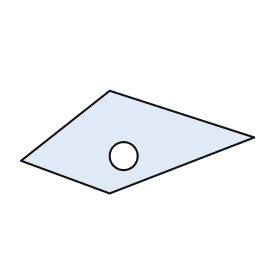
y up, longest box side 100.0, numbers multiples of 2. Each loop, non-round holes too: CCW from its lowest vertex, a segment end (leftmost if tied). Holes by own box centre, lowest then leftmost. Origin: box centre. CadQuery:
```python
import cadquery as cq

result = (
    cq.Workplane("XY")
    .moveTo(-12.0, -22.0)
    .lineTo(50.0, 2.0)
    .lineTo(-12.0, 22.0)
    .lineTo(-50.0, -8.0)
    .close()
    .moveTo(-6.0, -6.0)
    .circle(6.0)
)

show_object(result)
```